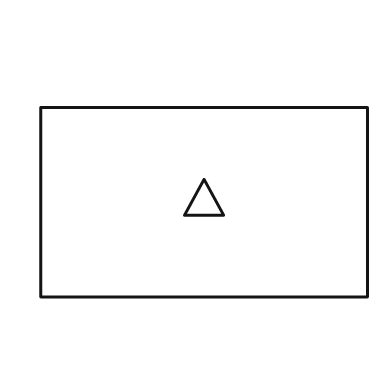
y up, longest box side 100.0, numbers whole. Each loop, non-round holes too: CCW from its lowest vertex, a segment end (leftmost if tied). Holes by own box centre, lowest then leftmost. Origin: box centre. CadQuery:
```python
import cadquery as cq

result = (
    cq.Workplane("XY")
    .moveTo(-50.0, -29.0)
    .lineTo(50.0, -29.0)
    .lineTo(50.0, 29.0)
    .lineTo(-50.0, 29.0)
    .close()
    .moveTo(-6.0, -4.0)
    .lineTo(6.0, -4.0)
    .lineTo(0.0, 7.0)
    .close()
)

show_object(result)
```